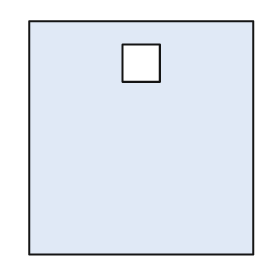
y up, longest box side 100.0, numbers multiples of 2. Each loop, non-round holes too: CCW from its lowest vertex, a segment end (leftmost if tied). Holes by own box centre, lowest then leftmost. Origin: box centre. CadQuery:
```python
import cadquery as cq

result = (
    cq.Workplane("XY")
    .moveTo(-48.0, -50.0)
    .lineTo(48.0, -50.0)
    .lineTo(48.0, 50.0)
    .lineTo(-48.0, 50.0)
    .close()
    .moveTo(-8.0, 24.0)
    .lineTo(8.0, 24.0)
    .lineTo(8.0, 40.0)
    .lineTo(-8.0, 40.0)
    .close()
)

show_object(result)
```